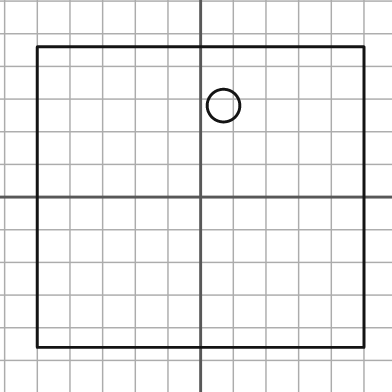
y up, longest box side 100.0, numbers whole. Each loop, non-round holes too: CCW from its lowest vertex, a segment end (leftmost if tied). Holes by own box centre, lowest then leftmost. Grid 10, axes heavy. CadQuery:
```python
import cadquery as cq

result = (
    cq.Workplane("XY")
    .moveTo(-50.0, -46.0)
    .lineTo(50.0, -46.0)
    .lineTo(50.0, 46.0)
    .lineTo(-50.0, 46.0)
    .close()
    .moveTo(7.0, 28.0)
    .circle(5.0)
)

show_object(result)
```